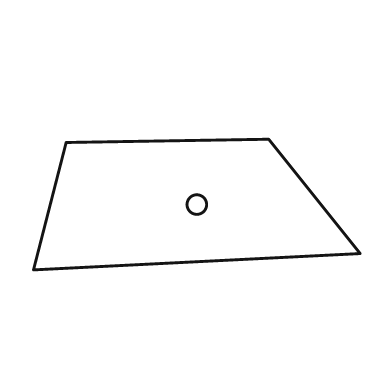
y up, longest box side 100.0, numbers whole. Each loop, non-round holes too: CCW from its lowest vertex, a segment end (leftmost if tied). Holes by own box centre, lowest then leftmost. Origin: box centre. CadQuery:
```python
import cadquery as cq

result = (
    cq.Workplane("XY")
    .moveTo(-50.0, -20.0)
    .lineTo(50.0, -15.0)
    .lineTo(22.0, 20.0)
    .lineTo(-40.0, 19.0)
    .close()
    .moveTo(0.0, 0.0)
    .circle(3.0)
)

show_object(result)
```